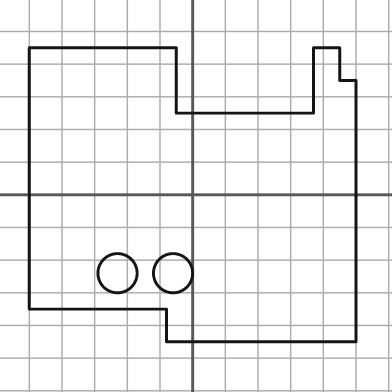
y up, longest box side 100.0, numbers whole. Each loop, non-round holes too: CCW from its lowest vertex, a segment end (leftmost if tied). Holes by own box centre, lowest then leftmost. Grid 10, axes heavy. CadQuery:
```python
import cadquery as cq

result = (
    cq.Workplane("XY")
    .moveTo(-8.0, -45.0)
    .lineTo(50.0, -45.0)
    .lineTo(50.0, 35.0)
    .lineTo(45.0, 35.0)
    .lineTo(45.0, 45.0)
    .lineTo(37.0, 45.0)
    .lineTo(37.0, 25.0)
    .lineTo(-5.0, 25.0)
    .lineTo(-5.0, 45.0)
    .lineTo(-50.0, 45.0)
    .lineTo(-50.0, -35.0)
    .lineTo(-8.0, -35.0)
    .close()
    .moveTo(-23.0, -24.0)
    .circle(6.0)
    .moveTo(-6.0, -24.0)
    .circle(6.0)
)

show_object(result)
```